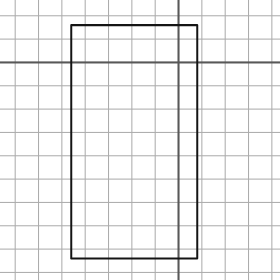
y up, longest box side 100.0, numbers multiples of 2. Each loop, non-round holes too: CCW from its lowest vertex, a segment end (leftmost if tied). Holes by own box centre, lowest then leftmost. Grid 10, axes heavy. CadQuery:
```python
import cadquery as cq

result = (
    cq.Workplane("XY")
    .moveTo(-46.0, -84.0)
    .lineTo(8.0, -84.0)
    .lineTo(8.0, 16.0)
    .lineTo(-46.0, 16.0)
    .close()
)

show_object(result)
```